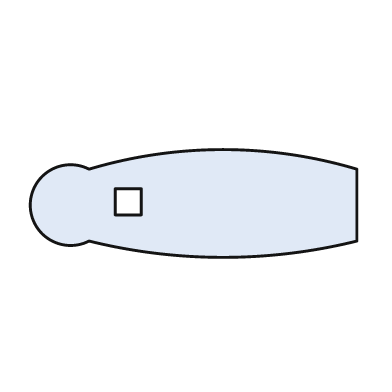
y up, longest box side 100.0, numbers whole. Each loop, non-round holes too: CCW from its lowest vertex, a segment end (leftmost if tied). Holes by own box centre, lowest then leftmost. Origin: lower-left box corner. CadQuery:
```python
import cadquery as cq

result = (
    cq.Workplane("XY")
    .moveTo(18.0, 5.0)
    .threePointArc((59.0, 0.0), (100.0, 5.0))
    .lineTo(100.0, 27.0)
    .threePointArc((59.0, 33.0), (18.0, 27.0))
    .threePointArc((0.0, 16.0), (18.0, 5.0))
    .close()
    .moveTo(26.0, 13.0)
    .lineTo(34.0, 13.0)
    .lineTo(34.0, 21.0)
    .lineTo(26.0, 21.0)
    .close()
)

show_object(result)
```